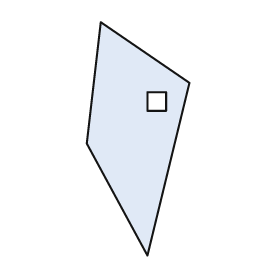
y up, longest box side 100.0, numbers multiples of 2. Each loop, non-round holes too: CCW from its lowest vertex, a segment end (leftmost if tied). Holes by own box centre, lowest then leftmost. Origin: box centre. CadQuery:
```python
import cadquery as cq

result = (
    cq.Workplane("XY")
    .moveTo(4.0, -50.0)
    .lineTo(22.0, 24.0)
    .lineTo(-16.0, 50.0)
    .lineTo(-22.0, -2.0)
    .close()
    .moveTo(4.0, 12.0)
    .lineTo(12.0, 12.0)
    .lineTo(12.0, 20.0)
    .lineTo(4.0, 20.0)
    .close()
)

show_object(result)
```